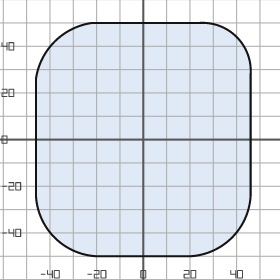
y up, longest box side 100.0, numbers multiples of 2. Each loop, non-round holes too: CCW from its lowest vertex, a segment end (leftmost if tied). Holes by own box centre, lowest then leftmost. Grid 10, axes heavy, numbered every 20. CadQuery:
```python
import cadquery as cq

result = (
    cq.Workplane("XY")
    .moveTo(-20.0, -50.0)
    .lineTo(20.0, -50.0)
    .threePointArc((38.0, -42.0), (46.0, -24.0))
    .lineTo(46.0, 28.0)
    .threePointArc((40.0, 44.0), (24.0, 50.0))
    .lineTo(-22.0, 50.0)
    .threePointArc((-38.0, 42.0), (-46.0, 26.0))
    .lineTo(-46.0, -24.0)
    .threePointArc((-38.0, -42.0), (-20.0, -50.0))
    .close()
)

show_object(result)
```